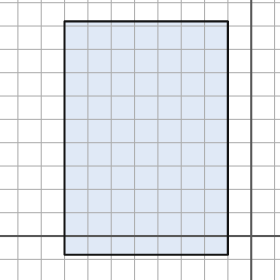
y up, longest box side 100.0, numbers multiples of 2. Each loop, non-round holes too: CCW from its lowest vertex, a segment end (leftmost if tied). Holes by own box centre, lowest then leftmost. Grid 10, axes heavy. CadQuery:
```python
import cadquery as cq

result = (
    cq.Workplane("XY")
    .moveTo(-80.0, -8.0)
    .lineTo(-10.0, -8.0)
    .lineTo(-10.0, 92.0)
    .lineTo(-80.0, 92.0)
    .close()
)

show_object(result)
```